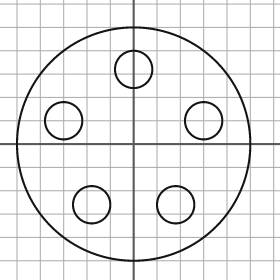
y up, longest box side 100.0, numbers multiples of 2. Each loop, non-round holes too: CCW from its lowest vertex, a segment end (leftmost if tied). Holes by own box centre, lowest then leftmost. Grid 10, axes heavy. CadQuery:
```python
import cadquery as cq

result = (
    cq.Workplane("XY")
    .moveTo(0.0, 0.0)
    .circle(50.0)
    .moveTo(-18.0, -26.0)
    .circle(8.0)
    .moveTo(18.0, -26.0)
    .circle(8.0)
    .moveTo(-30.0, 10.0)
    .circle(8.0)
    .moveTo(30.0, 10.0)
    .circle(8.0)
    .moveTo(0.0, 32.0)
    .circle(8.0)
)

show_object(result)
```